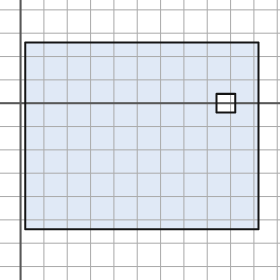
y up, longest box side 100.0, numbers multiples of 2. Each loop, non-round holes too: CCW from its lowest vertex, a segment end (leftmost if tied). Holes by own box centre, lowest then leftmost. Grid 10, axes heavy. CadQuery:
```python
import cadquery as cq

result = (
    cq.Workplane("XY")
    .moveTo(2.0, -54.0)
    .lineTo(102.0, -54.0)
    .lineTo(102.0, 26.0)
    .lineTo(2.0, 26.0)
    .close()
    .moveTo(84.0, -4.0)
    .lineTo(92.0, -4.0)
    .lineTo(92.0, 4.0)
    .lineTo(84.0, 4.0)
    .close()
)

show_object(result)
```